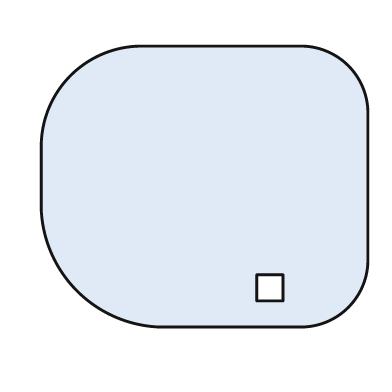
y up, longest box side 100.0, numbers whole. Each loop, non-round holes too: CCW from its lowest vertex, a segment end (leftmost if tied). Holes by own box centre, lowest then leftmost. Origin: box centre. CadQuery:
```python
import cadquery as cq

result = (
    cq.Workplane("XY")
    .moveTo(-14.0, -43.0)
    .lineTo(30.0, -43.0)
    .threePointArc((44.0, -37.0), (50.0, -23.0))
    .lineTo(50.0, 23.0)
    .threePointArc((44.0, 37.0), (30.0, 43.0))
    .lineTo(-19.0, 43.0)
    .threePointArc((-41.0, 34.0), (-50.0, 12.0))
    .lineTo(-50.0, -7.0)
    .threePointArc((-39.0, -32.0), (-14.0, -43.0))
    .close()
    .moveTo(16.0, -35.0)
    .lineTo(24.0, -35.0)
    .lineTo(24.0, -27.0)
    .lineTo(16.0, -27.0)
    .close()
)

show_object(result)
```